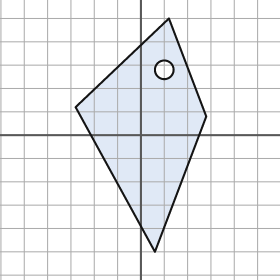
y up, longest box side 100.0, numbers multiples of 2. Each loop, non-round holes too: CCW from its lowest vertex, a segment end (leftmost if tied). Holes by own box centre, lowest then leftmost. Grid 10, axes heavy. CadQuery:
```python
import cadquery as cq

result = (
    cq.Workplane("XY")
    .moveTo(6.0, -50.0)
    .lineTo(28.0, 8.0)
    .lineTo(12.0, 50.0)
    .lineTo(-28.0, 12.0)
    .close()
    .moveTo(10.0, 28.0)
    .circle(4.0)
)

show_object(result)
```